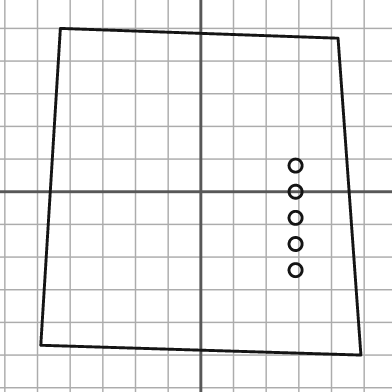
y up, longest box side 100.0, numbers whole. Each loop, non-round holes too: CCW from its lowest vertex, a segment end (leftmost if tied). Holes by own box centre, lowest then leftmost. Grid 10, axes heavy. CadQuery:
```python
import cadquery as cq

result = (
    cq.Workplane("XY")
    .moveTo(49.0, -50.0)
    .lineTo(42.0, 47.0)
    .lineTo(-43.0, 50.0)
    .lineTo(-49.0, -47.0)
    .close()
    .moveTo(29.0, -24.0)
    .circle(2.0)
    .moveTo(29.0, -16.0)
    .circle(2.0)
    .moveTo(29.0, -8.0)
    .circle(2.0)
    .moveTo(29.0, 0.0)
    .circle(2.0)
    .moveTo(29.0, 8.0)
    .circle(2.0)
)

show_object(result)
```